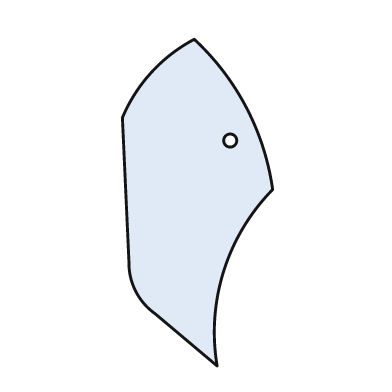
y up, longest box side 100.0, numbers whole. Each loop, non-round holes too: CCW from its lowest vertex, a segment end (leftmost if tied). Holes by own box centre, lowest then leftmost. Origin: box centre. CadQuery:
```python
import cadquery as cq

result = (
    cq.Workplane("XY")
    .moveTo(6.0, -50.0)
    .threePointArc((8.0, -21.0), (23.0, 4.0))
    .threePointArc((15.0, 29.0), (-1.0, 50.0))
    .threePointArc((-14.0, 40.0), (-23.0, 26.0))
    .lineTo(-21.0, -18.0)
    .threePointArc((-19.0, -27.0), (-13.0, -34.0))
    .close()
    .moveTo(10.0, 19.0)
    .circle(2.0)
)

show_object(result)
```